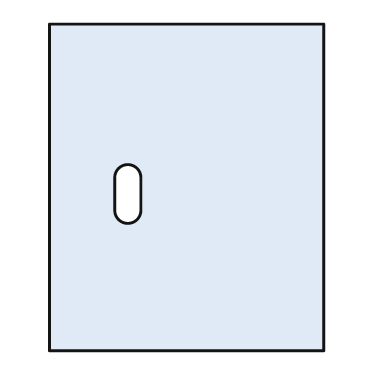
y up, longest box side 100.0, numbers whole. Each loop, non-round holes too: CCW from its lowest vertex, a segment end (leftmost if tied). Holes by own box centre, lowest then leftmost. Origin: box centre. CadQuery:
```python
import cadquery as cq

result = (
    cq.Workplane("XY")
    .moveTo(-42.0, -50.0)
    .lineTo(42.0, -50.0)
    .lineTo(42.0, 50.0)
    .lineTo(-42.0, 50.0)
    .close()
    .moveTo(-22.0, -7.0)
    .threePointArc((-18.0, -11.0), (-14.0, -7.0))
    .lineTo(-14.0, 3.0)
    .threePointArc((-18.0, 7.0), (-22.0, 3.0))
    .close()
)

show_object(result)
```